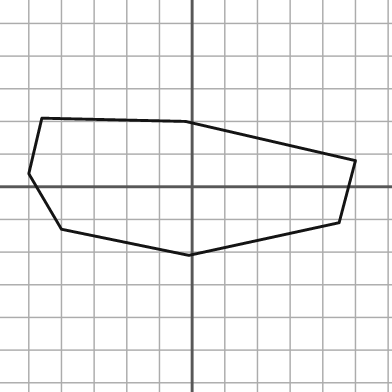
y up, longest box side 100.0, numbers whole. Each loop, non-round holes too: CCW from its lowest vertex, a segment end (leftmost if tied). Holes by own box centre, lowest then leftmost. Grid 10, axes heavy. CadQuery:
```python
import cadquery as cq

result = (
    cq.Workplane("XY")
    .moveTo(-1.0, -21.0)
    .lineTo(45.0, -11.0)
    .lineTo(50.0, 8.0)
    .lineTo(-2.0, 20.0)
    .lineTo(-46.0, 21.0)
    .lineTo(-50.0, 4.0)
    .lineTo(-40.0, -13.0)
    .close()
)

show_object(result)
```